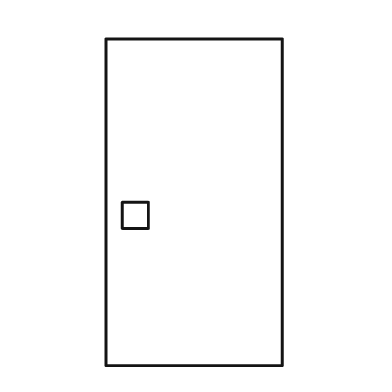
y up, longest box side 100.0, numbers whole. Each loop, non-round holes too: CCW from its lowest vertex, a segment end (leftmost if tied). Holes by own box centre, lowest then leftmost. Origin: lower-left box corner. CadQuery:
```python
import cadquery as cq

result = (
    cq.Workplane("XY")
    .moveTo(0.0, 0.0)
    .lineTo(54.0, 0.0)
    .lineTo(54.0, 100.0)
    .lineTo(0.0, 100.0)
    .close()
    .moveTo(5.0, 42.0)
    .lineTo(13.0, 42.0)
    .lineTo(13.0, 50.0)
    .lineTo(5.0, 50.0)
    .close()
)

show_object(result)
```